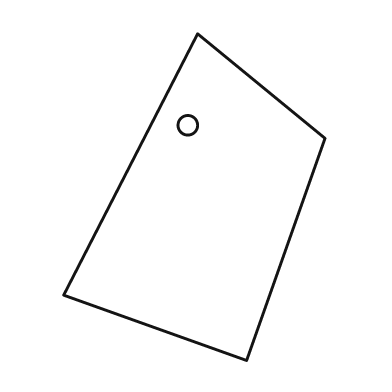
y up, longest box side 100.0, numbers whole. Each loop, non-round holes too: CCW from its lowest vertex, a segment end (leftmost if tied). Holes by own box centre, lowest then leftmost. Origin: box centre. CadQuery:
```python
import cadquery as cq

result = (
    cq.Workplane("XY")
    .moveTo(16.0, -50.0)
    .lineTo(40.0, 18.0)
    .lineTo(1.0, 50.0)
    .lineTo(-40.0, -30.0)
    .close()
    .moveTo(-2.0, 22.0)
    .circle(3.0)
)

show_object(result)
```